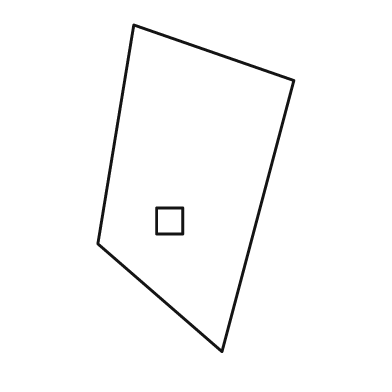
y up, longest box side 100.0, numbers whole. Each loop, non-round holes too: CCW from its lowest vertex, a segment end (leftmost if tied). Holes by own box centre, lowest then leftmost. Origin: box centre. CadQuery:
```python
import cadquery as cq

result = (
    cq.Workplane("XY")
    .moveTo(8.0, -50.0)
    .lineTo(30.0, 33.0)
    .lineTo(-19.0, 50.0)
    .lineTo(-30.0, -17.0)
    .close()
    .moveTo(-12.0, -14.0)
    .lineTo(-4.0, -14.0)
    .lineTo(-4.0, -6.0)
    .lineTo(-12.0, -6.0)
    .close()
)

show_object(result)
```